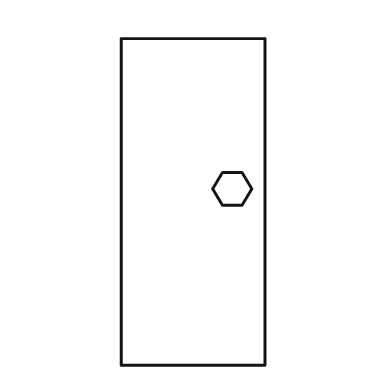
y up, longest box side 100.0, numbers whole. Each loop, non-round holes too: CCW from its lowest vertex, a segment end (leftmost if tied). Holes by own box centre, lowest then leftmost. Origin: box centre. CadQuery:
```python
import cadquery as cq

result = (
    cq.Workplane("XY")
    .moveTo(-22.0, -50.0)
    .lineTo(22.0, -50.0)
    .lineTo(22.0, 50.0)
    .lineTo(-22.0, 50.0)
    .close()
    .moveTo(9.0, -1.0)
    .lineTo(15.0, -1.0)
    .lineTo(18.0, 4.0)
    .lineTo(15.0, 9.0)
    .lineTo(9.0, 9.0)
    .lineTo(6.0, 4.0)
    .close()
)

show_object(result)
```